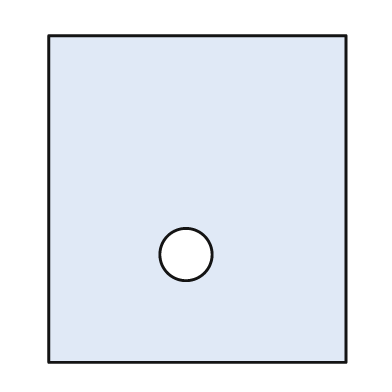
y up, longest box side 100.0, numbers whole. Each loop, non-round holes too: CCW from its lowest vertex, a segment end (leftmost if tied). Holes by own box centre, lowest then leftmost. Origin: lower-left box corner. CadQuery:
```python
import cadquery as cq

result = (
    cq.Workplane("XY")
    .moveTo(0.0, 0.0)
    .lineTo(91.0, 0.0)
    .lineTo(91.0, 100.0)
    .lineTo(0.0, 100.0)
    .close()
    .moveTo(42.0, 33.0)
    .circle(8.0)
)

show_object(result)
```